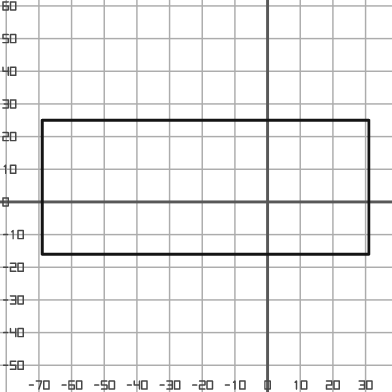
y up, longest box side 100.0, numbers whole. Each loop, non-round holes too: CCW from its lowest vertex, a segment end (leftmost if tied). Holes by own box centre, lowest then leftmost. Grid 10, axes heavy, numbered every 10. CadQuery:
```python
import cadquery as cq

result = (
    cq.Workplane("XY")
    .moveTo(-69.0, -16.0)
    .lineTo(31.0, -16.0)
    .lineTo(31.0, 25.0)
    .lineTo(-69.0, 25.0)
    .close()
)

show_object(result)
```